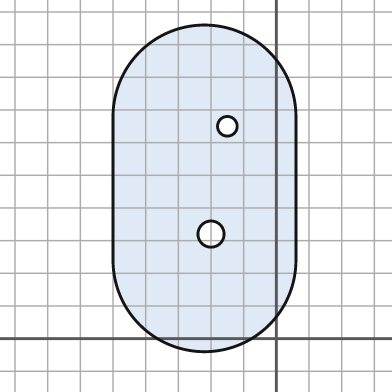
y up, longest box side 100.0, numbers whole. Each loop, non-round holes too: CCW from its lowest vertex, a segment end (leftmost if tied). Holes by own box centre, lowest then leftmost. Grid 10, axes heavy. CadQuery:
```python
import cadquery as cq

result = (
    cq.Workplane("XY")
    .moveTo(-50.0, 24.0)
    .threePointArc((-22.0, -4.0), (6.0, 24.0))
    .lineTo(6.0, 68.0)
    .threePointArc((-22.0, 96.0), (-50.0, 68.0))
    .close()
    .moveTo(-20.0, 32.0)
    .circle(4.0)
    .moveTo(-15.0, 65.0)
    .circle(3.0)
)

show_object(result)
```